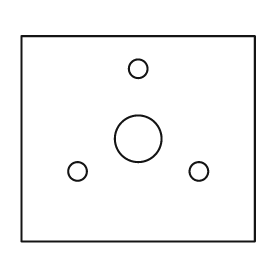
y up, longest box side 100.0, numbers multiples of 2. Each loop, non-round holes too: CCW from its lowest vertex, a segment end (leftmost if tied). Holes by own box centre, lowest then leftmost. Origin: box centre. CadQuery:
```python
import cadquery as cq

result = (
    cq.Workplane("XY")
    .moveTo(-50.0, -44.0)
    .lineTo(50.0, -44.0)
    .lineTo(50.0, 44.0)
    .lineTo(-50.0, 44.0)
    .close()
    .moveTo(-26.0, -14.0)
    .circle(4.0)
    .moveTo(26.0, -14.0)
    .circle(4.0)
    .moveTo(0.0, 0.0)
    .circle(10.0)
    .moveTo(0.0, 30.0)
    .circle(4.0)
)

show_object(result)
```